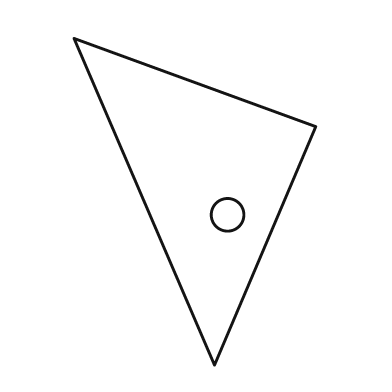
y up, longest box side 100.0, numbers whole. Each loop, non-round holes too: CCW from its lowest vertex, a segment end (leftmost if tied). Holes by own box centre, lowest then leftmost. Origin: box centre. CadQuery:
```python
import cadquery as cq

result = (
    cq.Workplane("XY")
    .moveTo(6.0, -50.0)
    .lineTo(37.0, 23.0)
    .lineTo(-37.0, 50.0)
    .close()
    .moveTo(10.0, -4.0)
    .circle(5.0)
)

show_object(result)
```